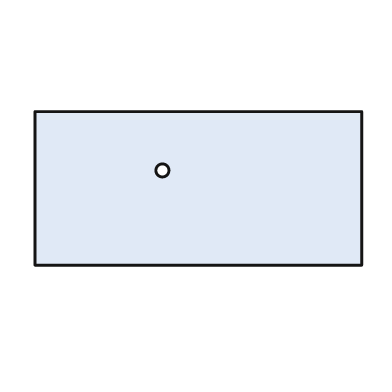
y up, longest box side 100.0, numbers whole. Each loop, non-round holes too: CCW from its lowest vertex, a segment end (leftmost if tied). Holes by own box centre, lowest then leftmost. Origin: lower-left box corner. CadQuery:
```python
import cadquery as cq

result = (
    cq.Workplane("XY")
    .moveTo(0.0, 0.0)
    .lineTo(100.0, 0.0)
    .lineTo(100.0, 47.0)
    .lineTo(0.0, 47.0)
    .close()
    .moveTo(39.0, 29.0)
    .circle(2.0)
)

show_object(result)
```